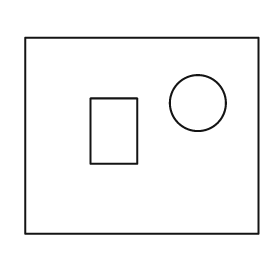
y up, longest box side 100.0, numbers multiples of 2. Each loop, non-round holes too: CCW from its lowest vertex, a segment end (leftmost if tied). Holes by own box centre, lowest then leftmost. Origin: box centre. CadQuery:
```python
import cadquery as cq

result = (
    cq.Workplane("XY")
    .moveTo(-50.0, -42.0)
    .lineTo(50.0, -42.0)
    .lineTo(50.0, 42.0)
    .lineTo(-50.0, 42.0)
    .close()
    .moveTo(-22.0, -12.0)
    .lineTo(-2.0, -12.0)
    .lineTo(-2.0, 16.0)
    .lineTo(-22.0, 16.0)
    .close()
    .moveTo(24.0, 14.0)
    .circle(12.0)
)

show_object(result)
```